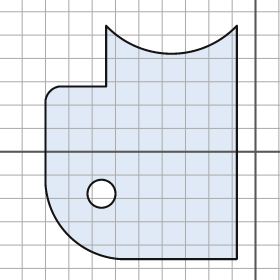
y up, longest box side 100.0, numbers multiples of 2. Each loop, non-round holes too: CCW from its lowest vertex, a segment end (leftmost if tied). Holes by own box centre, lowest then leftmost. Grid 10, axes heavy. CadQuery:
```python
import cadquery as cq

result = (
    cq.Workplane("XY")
    .moveTo(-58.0, -46.0)
    .lineTo(-8.0, -46.0)
    .lineTo(-8.0, 54.0)
    .threePointArc((-36.0, 42.0), (-64.0, 54.0))
    .lineTo(-64.0, 28.0)
    .lineTo(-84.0, 28.0)
    .threePointArc((-88.0, 26.0), (-90.0, 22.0))
    .lineTo(-90.0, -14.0)
    .threePointArc((-80.0, -36.0), (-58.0, -46.0))
    .close()
    .moveTo(-66.0, -18.0)
    .circle(6.0)
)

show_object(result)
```